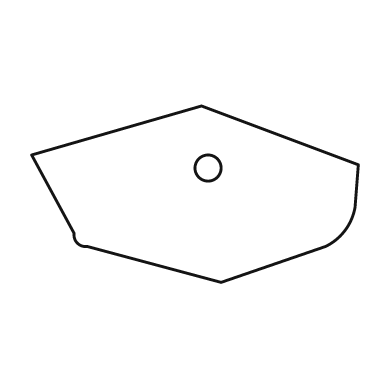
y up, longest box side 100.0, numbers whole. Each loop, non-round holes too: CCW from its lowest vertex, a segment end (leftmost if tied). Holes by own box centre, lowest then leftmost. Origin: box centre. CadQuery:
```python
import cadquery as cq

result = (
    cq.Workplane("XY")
    .moveTo(8.0, -27.0)
    .lineTo(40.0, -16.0)
    .threePointArc((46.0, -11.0), (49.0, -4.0))
    .lineTo(50.0, 9.0)
    .lineTo(2.0, 27.0)
    .lineTo(-50.0, 12.0)
    .lineTo(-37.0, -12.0)
    .threePointArc((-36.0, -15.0), (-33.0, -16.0))
    .close()
    .moveTo(4.0, 8.0)
    .circle(4.0)
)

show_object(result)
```